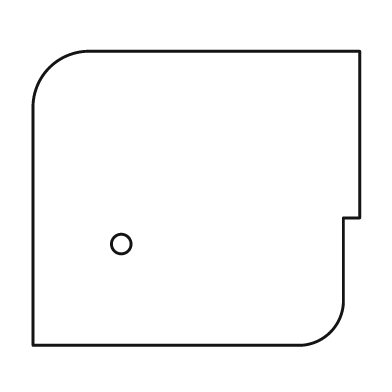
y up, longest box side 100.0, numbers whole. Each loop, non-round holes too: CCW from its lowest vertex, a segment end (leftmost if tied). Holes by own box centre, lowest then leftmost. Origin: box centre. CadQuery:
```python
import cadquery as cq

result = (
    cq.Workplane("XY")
    .moveTo(-50.0, -45.0)
    .lineTo(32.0, -45.0)
    .threePointArc((41.0, -41.0), (45.0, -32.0))
    .lineTo(45.0, -6.0)
    .lineTo(50.0, -6.0)
    .lineTo(50.0, 45.0)
    .lineTo(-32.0, 45.0)
    .threePointArc((-45.0, 40.0), (-50.0, 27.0))
    .close()
    .moveTo(-23.0, -14.0)
    .circle(3.0)
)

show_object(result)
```